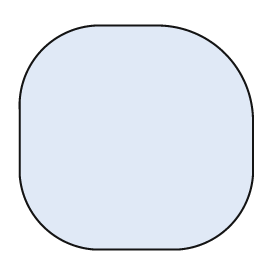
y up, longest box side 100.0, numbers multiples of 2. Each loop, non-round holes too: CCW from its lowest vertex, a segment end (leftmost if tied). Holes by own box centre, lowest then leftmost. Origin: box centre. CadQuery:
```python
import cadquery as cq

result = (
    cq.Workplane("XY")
    .moveTo(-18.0, -48.0)
    .lineTo(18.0, -48.0)
    .threePointArc((40.0, -38.0), (50.0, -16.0))
    .lineTo(50.0, 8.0)
    .threePointArc((38.0, 36.0), (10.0, 48.0))
    .lineTo(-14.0, 48.0)
    .threePointArc((-40.0, 38.0), (-50.0, 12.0))
    .lineTo(-50.0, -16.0)
    .threePointArc((-40.0, -38.0), (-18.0, -48.0))
    .close()
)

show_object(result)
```